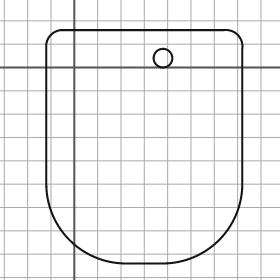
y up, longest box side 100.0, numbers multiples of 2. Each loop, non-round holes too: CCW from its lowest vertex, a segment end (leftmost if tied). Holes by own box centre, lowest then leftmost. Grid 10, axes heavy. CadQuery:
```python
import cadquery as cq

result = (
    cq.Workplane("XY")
    .moveTo(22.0, -84.0)
    .lineTo(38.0, -84.0)
    .threePointArc((62.0, -74.0), (72.0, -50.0))
    .lineTo(72.0, 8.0)
    .threePointArc((70.0, 14.0), (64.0, 16.0))
    .lineTo(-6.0, 16.0)
    .threePointArc((-10.0, 14.0), (-12.0, 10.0))
    .lineTo(-12.0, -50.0)
    .threePointArc((-2.0, -74.0), (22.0, -84.0))
    .close()
    .moveTo(38.0, 4.0)
    .circle(4.0)
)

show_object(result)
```